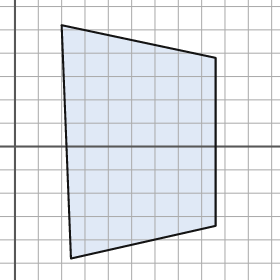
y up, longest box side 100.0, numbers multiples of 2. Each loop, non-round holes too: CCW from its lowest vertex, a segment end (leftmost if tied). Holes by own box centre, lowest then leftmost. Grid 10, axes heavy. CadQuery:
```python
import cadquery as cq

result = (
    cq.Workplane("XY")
    .moveTo(24.0, -48.0)
    .lineTo(86.0, -34.0)
    .lineTo(86.0, 38.0)
    .lineTo(20.0, 52.0)
    .close()
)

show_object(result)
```